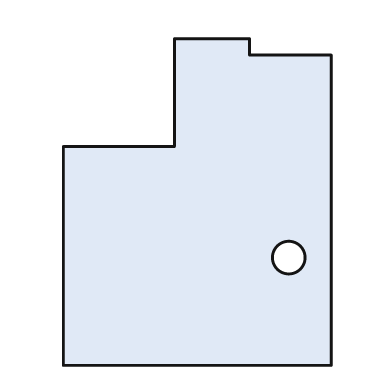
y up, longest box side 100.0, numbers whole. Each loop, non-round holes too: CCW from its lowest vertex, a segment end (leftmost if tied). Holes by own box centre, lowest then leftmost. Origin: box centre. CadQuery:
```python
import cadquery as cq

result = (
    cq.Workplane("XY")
    .moveTo(-41.0, -50.0)
    .lineTo(41.0, -50.0)
    .lineTo(41.0, 45.0)
    .lineTo(16.0, 45.0)
    .lineTo(16.0, 50.0)
    .lineTo(-7.0, 50.0)
    .lineTo(-7.0, 17.0)
    .lineTo(-41.0, 17.0)
    .close()
    .moveTo(28.0, -17.0)
    .circle(5.0)
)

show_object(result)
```